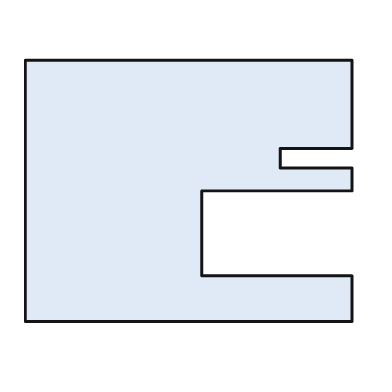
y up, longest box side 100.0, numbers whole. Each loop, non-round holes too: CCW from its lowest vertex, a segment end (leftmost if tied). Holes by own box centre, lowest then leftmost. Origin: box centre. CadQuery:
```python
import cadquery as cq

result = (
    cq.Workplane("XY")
    .moveTo(-50.0, -40.0)
    .lineTo(50.0, -40.0)
    .lineTo(50.0, -26.0)
    .lineTo(4.0, -26.0)
    .lineTo(4.0, 0.0)
    .lineTo(50.0, 0.0)
    .lineTo(50.0, 7.0)
    .lineTo(28.0, 7.0)
    .lineTo(28.0, 13.0)
    .lineTo(50.0, 13.0)
    .lineTo(50.0, 40.0)
    .lineTo(-50.0, 40.0)
    .close()
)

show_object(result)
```